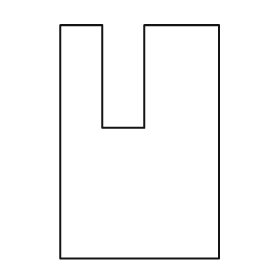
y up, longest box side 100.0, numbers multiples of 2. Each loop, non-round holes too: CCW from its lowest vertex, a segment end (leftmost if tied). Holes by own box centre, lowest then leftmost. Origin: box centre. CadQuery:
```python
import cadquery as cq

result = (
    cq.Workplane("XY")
    .moveTo(-34.0, -50.0)
    .lineTo(34.0, -50.0)
    .lineTo(34.0, 50.0)
    .lineTo(2.0, 50.0)
    .lineTo(2.0, 6.0)
    .lineTo(-16.0, 6.0)
    .lineTo(-16.0, 50.0)
    .lineTo(-34.0, 50.0)
    .close()
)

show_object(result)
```